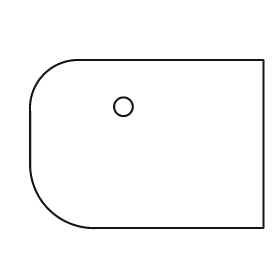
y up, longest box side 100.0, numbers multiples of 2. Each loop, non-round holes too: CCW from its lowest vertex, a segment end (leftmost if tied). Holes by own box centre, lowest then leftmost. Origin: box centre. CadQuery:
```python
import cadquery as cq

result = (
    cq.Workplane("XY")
    .moveTo(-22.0, -36.0)
    .lineTo(50.0, -36.0)
    .lineTo(50.0, 36.0)
    .lineTo(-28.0, 36.0)
    .threePointArc((-44.0, 30.0), (-50.0, 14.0))
    .lineTo(-50.0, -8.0)
    .threePointArc((-42.0, -28.0), (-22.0, -36.0))
    .close()
    .moveTo(-10.0, 16.0)
    .circle(4.0)
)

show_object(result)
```